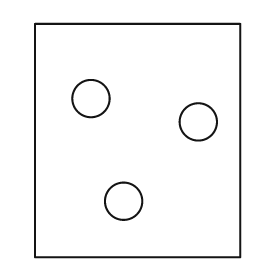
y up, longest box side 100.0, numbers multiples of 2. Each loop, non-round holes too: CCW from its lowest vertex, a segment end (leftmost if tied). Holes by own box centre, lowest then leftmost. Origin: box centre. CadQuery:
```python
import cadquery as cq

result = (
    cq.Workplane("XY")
    .moveTo(-44.0, -50.0)
    .lineTo(44.0, -50.0)
    .lineTo(44.0, 50.0)
    .lineTo(-44.0, 50.0)
    .close()
    .moveTo(-6.0, -26.0)
    .circle(8.0)
    .moveTo(26.0, 8.0)
    .circle(8.0)
    .moveTo(-20.0, 18.0)
    .circle(8.0)
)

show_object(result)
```